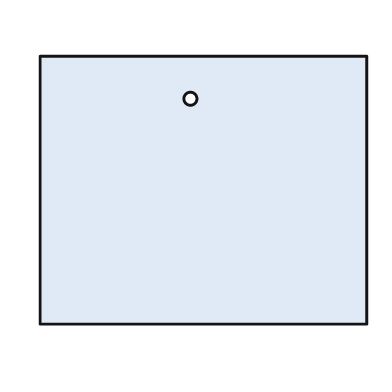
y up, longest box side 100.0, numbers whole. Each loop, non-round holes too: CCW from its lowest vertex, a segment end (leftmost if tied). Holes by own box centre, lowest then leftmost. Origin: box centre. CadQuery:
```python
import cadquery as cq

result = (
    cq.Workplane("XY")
    .moveTo(-50.0, -41.0)
    .lineTo(50.0, -41.0)
    .lineTo(50.0, 41.0)
    .lineTo(-50.0, 41.0)
    .close()
    .moveTo(-4.0, 28.0)
    .circle(2.0)
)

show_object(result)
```